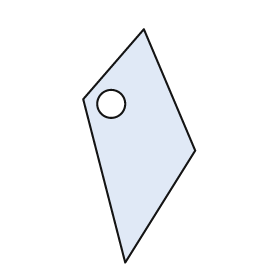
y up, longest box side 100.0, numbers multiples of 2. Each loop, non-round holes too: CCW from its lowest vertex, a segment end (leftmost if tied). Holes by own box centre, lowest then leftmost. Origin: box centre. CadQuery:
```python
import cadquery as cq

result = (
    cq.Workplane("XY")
    .moveTo(-6.0, -50.0)
    .lineTo(24.0, -2.0)
    .lineTo(2.0, 50.0)
    .lineTo(-24.0, 20.0)
    .close()
    .moveTo(-12.0, 18.0)
    .circle(6.0)
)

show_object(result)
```